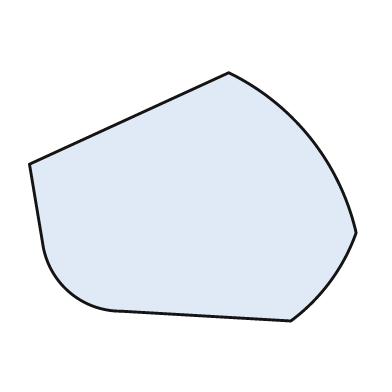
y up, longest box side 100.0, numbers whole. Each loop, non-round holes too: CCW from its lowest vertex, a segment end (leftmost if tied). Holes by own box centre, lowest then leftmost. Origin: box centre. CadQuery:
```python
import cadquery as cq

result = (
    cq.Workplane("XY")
    .moveTo(30.0, -38.0)
    .threePointArc((42.0, -26.0), (50.0, -11.0))
    .threePointArc((36.0, 18.0), (11.0, 38.0))
    .lineTo(-50.0, 10.0)
    .lineTo(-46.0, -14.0)
    .threePointArc((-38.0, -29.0), (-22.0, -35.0))
    .close()
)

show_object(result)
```